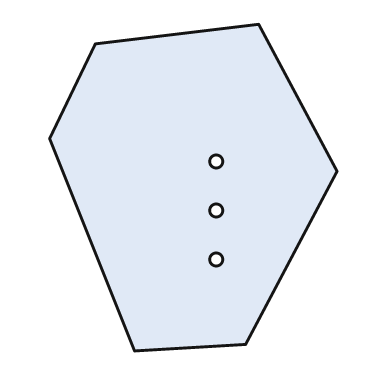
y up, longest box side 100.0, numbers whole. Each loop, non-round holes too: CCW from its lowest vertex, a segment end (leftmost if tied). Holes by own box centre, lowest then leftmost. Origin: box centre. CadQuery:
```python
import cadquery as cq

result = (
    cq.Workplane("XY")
    .moveTo(-18.0, -50.0)
    .lineTo(16.0, -48.0)
    .lineTo(44.0, 5.0)
    .lineTo(20.0, 50.0)
    .lineTo(-30.0, 44.0)
    .lineTo(-44.0, 15.0)
    .close()
    .moveTo(7.0, -22.0)
    .circle(2.0)
    .moveTo(7.0, -7.0)
    .circle(2.0)
    .moveTo(7.0, 8.0)
    .circle(2.0)
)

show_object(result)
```